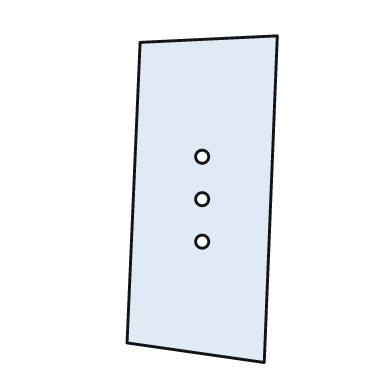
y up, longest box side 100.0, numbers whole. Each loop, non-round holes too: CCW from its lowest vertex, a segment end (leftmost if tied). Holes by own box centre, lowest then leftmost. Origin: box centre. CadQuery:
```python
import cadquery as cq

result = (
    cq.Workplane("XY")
    .moveTo(19.0, -50.0)
    .lineTo(23.0, 50.0)
    .lineTo(-19.0, 48.0)
    .lineTo(-23.0, -44.0)
    .close()
    .moveTo(0.0, -13.0)
    .circle(2.0)
    .moveTo(0.0, 0.0)
    .circle(2.0)
    .moveTo(0.0, 13.0)
    .circle(2.0)
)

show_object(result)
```